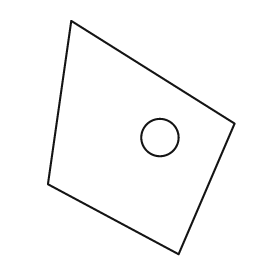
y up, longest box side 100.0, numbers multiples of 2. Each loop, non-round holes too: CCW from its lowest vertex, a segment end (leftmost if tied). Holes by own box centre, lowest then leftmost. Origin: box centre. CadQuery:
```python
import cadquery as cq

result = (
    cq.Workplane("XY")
    .moveTo(16.0, -50.0)
    .lineTo(40.0, 6.0)
    .lineTo(-30.0, 50.0)
    .lineTo(-40.0, -20.0)
    .close()
    .moveTo(8.0, 0.0)
    .circle(8.0)
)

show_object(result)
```